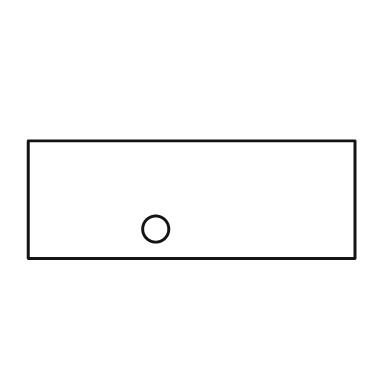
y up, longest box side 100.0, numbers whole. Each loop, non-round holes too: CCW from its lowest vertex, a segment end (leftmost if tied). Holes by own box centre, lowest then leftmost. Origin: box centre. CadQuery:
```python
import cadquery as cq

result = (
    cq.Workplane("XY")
    .moveTo(-50.0, -18.0)
    .lineTo(50.0, -18.0)
    .lineTo(50.0, 18.0)
    .lineTo(-50.0, 18.0)
    .close()
    .moveTo(-11.0, -9.0)
    .circle(4.0)
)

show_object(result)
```